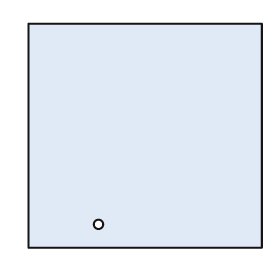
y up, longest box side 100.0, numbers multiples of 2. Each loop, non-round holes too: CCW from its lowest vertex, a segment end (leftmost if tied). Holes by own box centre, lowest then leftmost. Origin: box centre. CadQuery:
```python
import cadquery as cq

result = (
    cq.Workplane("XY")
    .moveTo(-50.0, -48.0)
    .lineTo(50.0, -48.0)
    .lineTo(50.0, 48.0)
    .lineTo(-50.0, 48.0)
    .close()
    .moveTo(-20.0, -38.0)
    .circle(2.0)
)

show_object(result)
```